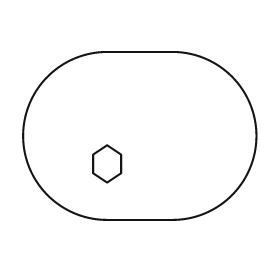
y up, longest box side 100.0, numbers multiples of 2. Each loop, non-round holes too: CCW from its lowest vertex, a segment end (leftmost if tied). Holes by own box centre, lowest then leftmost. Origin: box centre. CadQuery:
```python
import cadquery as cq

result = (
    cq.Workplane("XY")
    .moveTo(-14.0, -36.0)
    .lineTo(14.0, -36.0)
    .threePointArc((50.0, 0.0), (14.0, 36.0))
    .lineTo(-14.0, 36.0)
    .threePointArc((-50.0, 0.0), (-14.0, -36.0))
    .close()
    .moveTo(-14.0, -20.0)
    .lineTo(-8.0, -16.0)
    .lineTo(-8.0, -8.0)
    .lineTo(-14.0, -4.0)
    .lineTo(-20.0, -8.0)
    .lineTo(-20.0, -16.0)
    .close()
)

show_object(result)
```